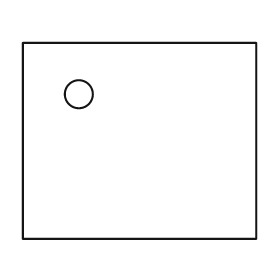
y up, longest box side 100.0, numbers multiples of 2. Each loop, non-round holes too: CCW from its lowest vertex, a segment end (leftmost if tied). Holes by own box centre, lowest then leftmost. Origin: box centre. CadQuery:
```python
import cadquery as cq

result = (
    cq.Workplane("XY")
    .moveTo(-50.0, -42.0)
    .lineTo(50.0, -42.0)
    .lineTo(50.0, 42.0)
    .lineTo(-50.0, 42.0)
    .close()
    .moveTo(-26.0, 20.0)
    .circle(6.0)
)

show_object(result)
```